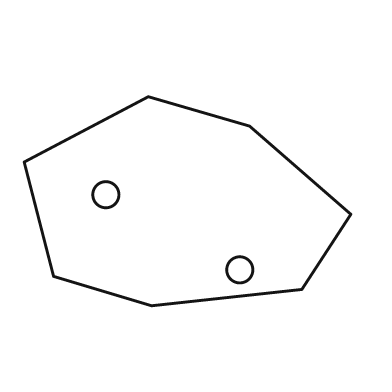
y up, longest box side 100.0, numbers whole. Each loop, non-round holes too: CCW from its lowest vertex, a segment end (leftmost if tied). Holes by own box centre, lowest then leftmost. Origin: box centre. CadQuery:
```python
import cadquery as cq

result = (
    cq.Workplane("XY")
    .moveTo(-11.0, -32.0)
    .lineTo(35.0, -27.0)
    .lineTo(50.0, -4.0)
    .lineTo(19.0, 23.0)
    .lineTo(-12.0, 32.0)
    .lineTo(-50.0, 12.0)
    .lineTo(-41.0, -23.0)
    .close()
    .moveTo(16.0, -21.0)
    .circle(4.0)
    .moveTo(-25.0, 2.0)
    .circle(4.0)
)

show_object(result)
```